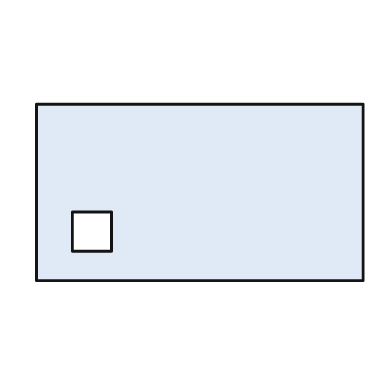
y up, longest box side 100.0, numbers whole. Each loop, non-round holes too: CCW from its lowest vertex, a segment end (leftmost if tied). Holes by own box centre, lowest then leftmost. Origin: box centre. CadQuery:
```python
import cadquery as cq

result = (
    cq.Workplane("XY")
    .moveTo(-50.0, -27.0)
    .lineTo(50.0, -27.0)
    .lineTo(50.0, 27.0)
    .lineTo(-50.0, 27.0)
    .close()
    .moveTo(-39.0, -18.0)
    .lineTo(-27.0, -18.0)
    .lineTo(-27.0, -6.0)
    .lineTo(-39.0, -6.0)
    .close()
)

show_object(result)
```